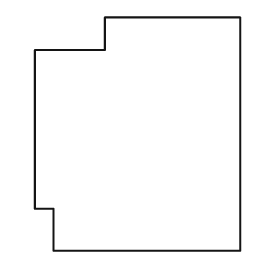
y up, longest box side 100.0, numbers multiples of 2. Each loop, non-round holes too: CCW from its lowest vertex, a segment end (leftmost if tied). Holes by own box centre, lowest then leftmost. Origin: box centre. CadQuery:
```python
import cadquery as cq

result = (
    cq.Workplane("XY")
    .moveTo(-36.0, -50.0)
    .lineTo(44.0, -50.0)
    .lineTo(44.0, 50.0)
    .lineTo(-14.0, 50.0)
    .lineTo(-14.0, 36.0)
    .lineTo(-44.0, 36.0)
    .lineTo(-44.0, -32.0)
    .lineTo(-36.0, -32.0)
    .close()
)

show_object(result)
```